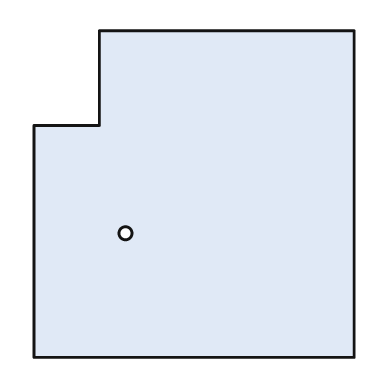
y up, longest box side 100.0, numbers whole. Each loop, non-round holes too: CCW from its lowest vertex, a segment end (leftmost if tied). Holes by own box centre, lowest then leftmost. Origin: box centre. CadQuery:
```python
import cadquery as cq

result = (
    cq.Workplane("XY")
    .moveTo(-49.0, -50.0)
    .lineTo(49.0, -50.0)
    .lineTo(49.0, 50.0)
    .lineTo(-29.0, 50.0)
    .lineTo(-29.0, 21.0)
    .lineTo(-49.0, 21.0)
    .close()
    .moveTo(-21.0, -12.0)
    .circle(2.0)
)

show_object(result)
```